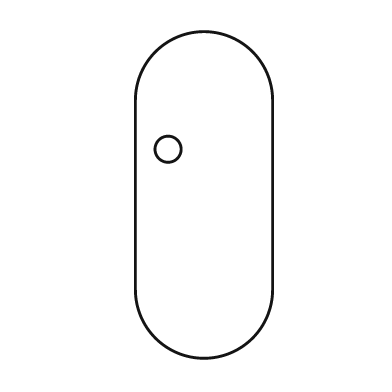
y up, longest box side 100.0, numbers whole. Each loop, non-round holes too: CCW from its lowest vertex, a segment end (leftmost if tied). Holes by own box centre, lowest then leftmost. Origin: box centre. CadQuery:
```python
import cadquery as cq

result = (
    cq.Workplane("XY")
    .moveTo(-21.0, -29.0)
    .threePointArc((0.0, -50.0), (21.0, -29.0))
    .lineTo(21.0, 29.0)
    .threePointArc((0.0, 50.0), (-21.0, 29.0))
    .close()
    .moveTo(-11.0, 14.0)
    .circle(4.0)
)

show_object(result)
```